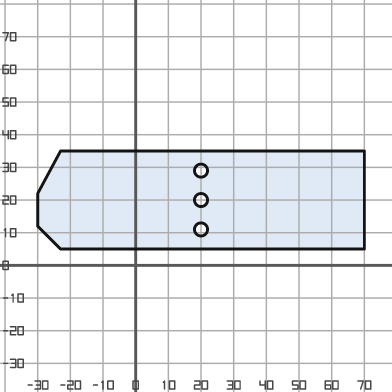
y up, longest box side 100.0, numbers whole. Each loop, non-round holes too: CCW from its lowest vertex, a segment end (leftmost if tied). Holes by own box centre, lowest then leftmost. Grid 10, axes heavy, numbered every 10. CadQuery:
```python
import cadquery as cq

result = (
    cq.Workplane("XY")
    .moveTo(-23.0, 5.0)
    .lineTo(70.0, 5.0)
    .lineTo(70.0, 35.0)
    .lineTo(-23.0, 35.0)
    .lineTo(-30.0, 22.0)
    .lineTo(-30.0, 12.0)
    .close()
    .moveTo(20.0, 11.0)
    .circle(2.0)
    .moveTo(20.0, 20.0)
    .circle(2.0)
    .moveTo(20.0, 29.0)
    .circle(2.0)
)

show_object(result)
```